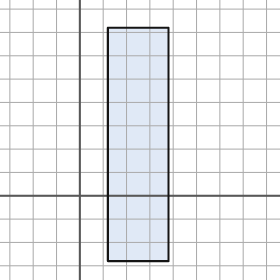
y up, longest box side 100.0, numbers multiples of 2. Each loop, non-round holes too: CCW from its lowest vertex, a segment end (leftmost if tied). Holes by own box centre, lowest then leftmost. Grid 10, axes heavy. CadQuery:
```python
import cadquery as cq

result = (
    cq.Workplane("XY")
    .moveTo(12.0, -28.0)
    .lineTo(38.0, -28.0)
    .lineTo(38.0, 72.0)
    .lineTo(12.0, 72.0)
    .close()
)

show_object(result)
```